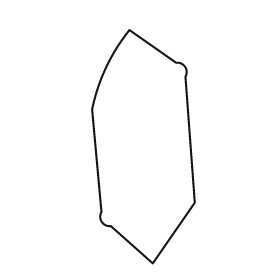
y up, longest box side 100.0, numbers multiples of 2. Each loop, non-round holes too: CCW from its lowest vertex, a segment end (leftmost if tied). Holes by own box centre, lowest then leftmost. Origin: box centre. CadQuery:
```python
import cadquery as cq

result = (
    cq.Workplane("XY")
    .moveTo(4.0, -50.0)
    .lineTo(22.0, -24.0)
    .lineTo(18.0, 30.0)
    .threePointArc((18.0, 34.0), (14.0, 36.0))
    .lineTo(-6.0, 50.0)
    .threePointArc((-16.0, 34.0), (-22.0, 16.0))
    .lineTo(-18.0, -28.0)
    .threePointArc((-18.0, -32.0), (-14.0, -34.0))
    .close()
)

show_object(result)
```